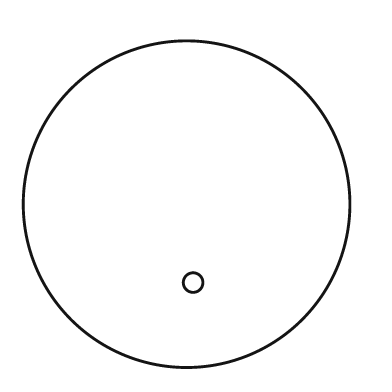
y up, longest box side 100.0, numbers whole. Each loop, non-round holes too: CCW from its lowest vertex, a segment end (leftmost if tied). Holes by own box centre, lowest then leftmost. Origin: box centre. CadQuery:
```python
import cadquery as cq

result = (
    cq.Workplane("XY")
    .moveTo(0.0, 0.0)
    .circle(50.0)
    .moveTo(2.0, -24.0)
    .circle(3.0)
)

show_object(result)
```